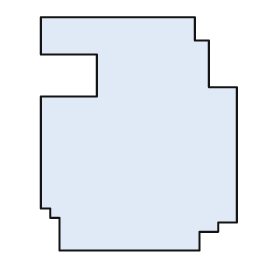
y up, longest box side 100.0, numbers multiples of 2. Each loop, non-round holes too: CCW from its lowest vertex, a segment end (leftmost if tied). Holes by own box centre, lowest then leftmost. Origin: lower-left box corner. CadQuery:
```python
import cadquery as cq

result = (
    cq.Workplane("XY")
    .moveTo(8.0, 0.0)
    .lineTo(68.0, 0.0)
    .lineTo(68.0, 8.0)
    .lineTo(76.0, 8.0)
    .lineTo(76.0, 12.0)
    .lineTo(84.0, 12.0)
    .lineTo(84.0, 70.0)
    .lineTo(72.0, 70.0)
    .lineTo(72.0, 90.0)
    .lineTo(66.0, 90.0)
    .lineTo(66.0, 100.0)
    .lineTo(0.0, 100.0)
    .lineTo(0.0, 84.0)
    .lineTo(24.0, 84.0)
    .lineTo(24.0, 66.0)
    .lineTo(0.0, 66.0)
    .lineTo(0.0, 18.0)
    .lineTo(4.0, 18.0)
    .lineTo(4.0, 14.0)
    .lineTo(8.0, 14.0)
    .close()
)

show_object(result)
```